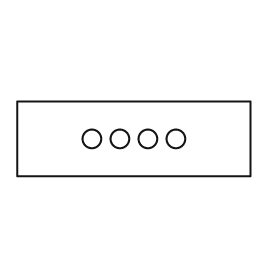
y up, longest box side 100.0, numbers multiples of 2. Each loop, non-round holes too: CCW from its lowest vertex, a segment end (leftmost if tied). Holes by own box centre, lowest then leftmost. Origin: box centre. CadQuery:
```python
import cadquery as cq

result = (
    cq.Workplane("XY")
    .moveTo(-50.0, -16.0)
    .lineTo(50.0, -16.0)
    .lineTo(50.0, 16.0)
    .lineTo(-50.0, 16.0)
    .close()
    .moveTo(-18.0, 0.0)
    .circle(4.0)
    .moveTo(-6.0, 0.0)
    .circle(4.0)
    .moveTo(6.0, 0.0)
    .circle(4.0)
    .moveTo(18.0, 0.0)
    .circle(4.0)
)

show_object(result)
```